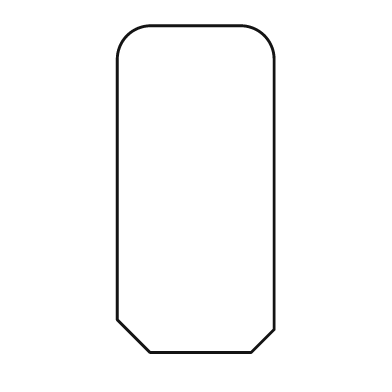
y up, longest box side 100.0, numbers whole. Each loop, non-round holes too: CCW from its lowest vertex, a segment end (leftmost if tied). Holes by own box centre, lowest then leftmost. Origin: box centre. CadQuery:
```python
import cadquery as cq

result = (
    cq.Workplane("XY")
    .moveTo(-14.0, -50.0)
    .lineTo(17.0, -50.0)
    .lineTo(24.0, -43.0)
    .lineTo(24.0, 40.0)
    .threePointArc((21.0, 47.0), (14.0, 50.0))
    .lineTo(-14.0, 50.0)
    .threePointArc((-21.0, 47.0), (-24.0, 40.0))
    .lineTo(-24.0, -40.0)
    .close()
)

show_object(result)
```